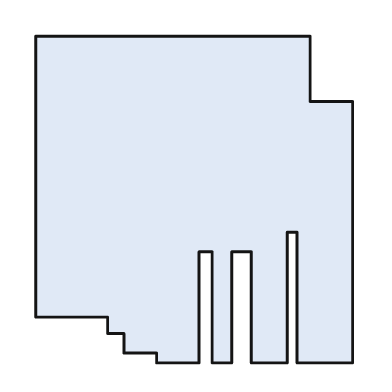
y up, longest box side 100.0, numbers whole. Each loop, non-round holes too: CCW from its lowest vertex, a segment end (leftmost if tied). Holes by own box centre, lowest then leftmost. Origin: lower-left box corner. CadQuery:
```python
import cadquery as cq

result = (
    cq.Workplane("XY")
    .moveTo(37.0, 0.0)
    .lineTo(50.0, 0.0)
    .lineTo(50.0, 34.0)
    .lineTo(54.0, 34.0)
    .lineTo(54.0, 0.0)
    .lineTo(60.0, 0.0)
    .lineTo(60.0, 34.0)
    .lineTo(66.0, 34.0)
    .lineTo(66.0, 0.0)
    .lineTo(77.0, 0.0)
    .lineTo(77.0, 40.0)
    .lineTo(80.0, 40.0)
    .lineTo(80.0, 0.0)
    .lineTo(97.0, 0.0)
    .lineTo(97.0, 80.0)
    .lineTo(84.0, 80.0)
    .lineTo(84.0, 100.0)
    .lineTo(0.0, 100.0)
    .lineTo(0.0, 14.0)
    .lineTo(22.0, 14.0)
    .lineTo(22.0, 9.0)
    .lineTo(27.0, 9.0)
    .lineTo(27.0, 3.0)
    .lineTo(37.0, 3.0)
    .close()
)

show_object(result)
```